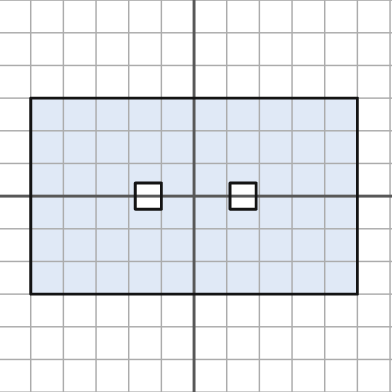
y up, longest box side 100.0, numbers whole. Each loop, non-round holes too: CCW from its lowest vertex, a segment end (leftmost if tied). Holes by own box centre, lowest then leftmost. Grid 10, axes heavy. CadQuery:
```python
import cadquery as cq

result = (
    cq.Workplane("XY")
    .moveTo(-50.0, -30.0)
    .lineTo(50.0, -30.0)
    .lineTo(50.0, 30.0)
    .lineTo(-50.0, 30.0)
    .close()
    .moveTo(-18.0, -4.0)
    .lineTo(-10.0, -4.0)
    .lineTo(-10.0, 4.0)
    .lineTo(-18.0, 4.0)
    .close()
    .moveTo(11.0, -4.0)
    .lineTo(19.0, -4.0)
    .lineTo(19.0, 4.0)
    .lineTo(11.0, 4.0)
    .close()
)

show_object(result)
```